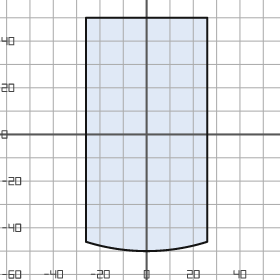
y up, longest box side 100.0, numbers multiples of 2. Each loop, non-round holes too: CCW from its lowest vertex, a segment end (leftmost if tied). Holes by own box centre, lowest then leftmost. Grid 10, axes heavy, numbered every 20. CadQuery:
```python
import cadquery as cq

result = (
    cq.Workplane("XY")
    .moveTo(-26.0, -46.0)
    .threePointArc((0.0, -50.0), (26.0, -46.0))
    .lineTo(26.0, 50.0)
    .lineTo(-26.0, 50.0)
    .close()
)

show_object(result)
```